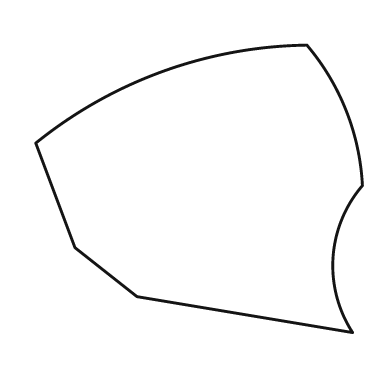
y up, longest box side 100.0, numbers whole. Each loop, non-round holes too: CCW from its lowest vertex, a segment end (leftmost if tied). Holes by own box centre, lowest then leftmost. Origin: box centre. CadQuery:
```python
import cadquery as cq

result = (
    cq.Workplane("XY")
    .moveTo(47.0, -44.0)
    .threePointArc((41.0, -21.0), (50.0, 1.0))
    .threePointArc((45.0, 24.0), (33.0, 44.0))
    .threePointArc((-11.0, 36.0), (-50.0, 14.0))
    .lineTo(-38.0, -18.0)
    .lineTo(-19.0, -33.0)
    .close()
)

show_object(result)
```